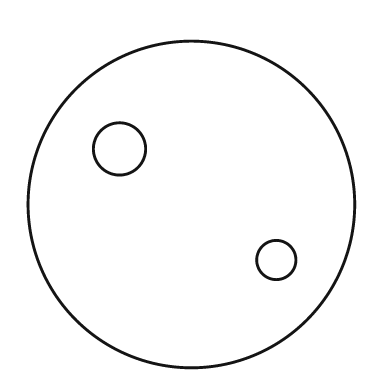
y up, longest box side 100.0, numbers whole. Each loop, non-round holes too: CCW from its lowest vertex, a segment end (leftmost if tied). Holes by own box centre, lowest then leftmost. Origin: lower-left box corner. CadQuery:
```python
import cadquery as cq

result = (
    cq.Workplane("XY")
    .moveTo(50.0, 50.0)
    .circle(50.0)
    .moveTo(76.0, 33.0)
    .circle(6.0)
    .moveTo(28.0, 67.0)
    .circle(8.0)
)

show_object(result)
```